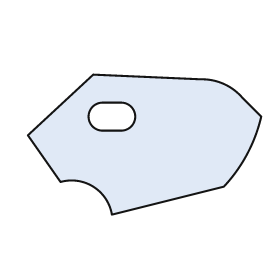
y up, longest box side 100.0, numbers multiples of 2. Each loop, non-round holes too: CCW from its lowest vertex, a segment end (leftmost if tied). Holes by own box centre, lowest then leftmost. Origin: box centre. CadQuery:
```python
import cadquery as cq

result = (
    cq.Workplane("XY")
    .moveTo(-14.0, -30.0)
    .lineTo(34.0, -18.0)
    .threePointArc((44.0, -4.0), (50.0, 12.0))
    .lineTo(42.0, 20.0)
    .threePointArc((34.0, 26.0), (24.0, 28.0))
    .lineTo(-22.0, 30.0)
    .lineTo(-50.0, 4.0)
    .lineTo(-36.0, -16.0)
    .threePointArc((-22.0, -18.0), (-14.0, -30.0))
    .close()
    .moveTo(-18.0, 6.0)
    .lineTo(-10.0, 6.0)
    .threePointArc((-4.0, 12.0), (-10.0, 18.0))
    .lineTo(-18.0, 18.0)
    .threePointArc((-24.0, 12.0), (-18.0, 6.0))
    .close()
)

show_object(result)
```